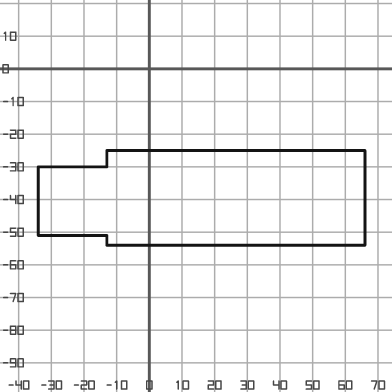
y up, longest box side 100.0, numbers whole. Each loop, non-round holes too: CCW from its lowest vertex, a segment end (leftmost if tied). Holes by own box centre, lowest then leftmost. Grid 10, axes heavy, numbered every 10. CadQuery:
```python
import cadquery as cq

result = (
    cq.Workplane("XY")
    .moveTo(-13.0, -54.0)
    .lineTo(66.0, -54.0)
    .lineTo(66.0, -25.0)
    .lineTo(-13.0, -25.0)
    .lineTo(-13.0, -30.0)
    .lineTo(-34.0, -30.0)
    .lineTo(-34.0, -51.0)
    .lineTo(-13.0, -51.0)
    .close()
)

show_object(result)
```